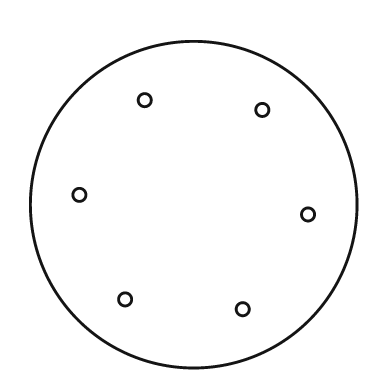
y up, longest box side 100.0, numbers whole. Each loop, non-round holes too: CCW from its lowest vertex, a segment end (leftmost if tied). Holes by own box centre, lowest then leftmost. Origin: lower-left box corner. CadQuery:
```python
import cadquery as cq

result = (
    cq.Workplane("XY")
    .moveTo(50.0, 50.0)
    .circle(50.0)
    .moveTo(65.0, 18.0)
    .circle(2.0)
    .moveTo(29.0, 21.0)
    .circle(2.0)
    .moveTo(85.0, 47.0)
    .circle(2.0)
    .moveTo(15.0, 53.0)
    .circle(2.0)
    .moveTo(71.0, 79.0)
    .circle(2.0)
    .moveTo(35.0, 82.0)
    .circle(2.0)
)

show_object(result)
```